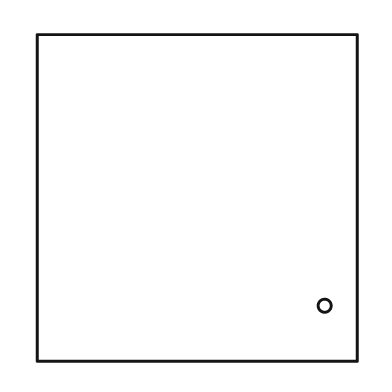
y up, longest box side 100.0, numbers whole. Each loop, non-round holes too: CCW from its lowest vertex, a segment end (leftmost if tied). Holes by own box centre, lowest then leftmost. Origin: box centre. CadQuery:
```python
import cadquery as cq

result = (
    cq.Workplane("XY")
    .moveTo(-49.0, -50.0)
    .lineTo(49.0, -50.0)
    .lineTo(49.0, 50.0)
    .lineTo(-49.0, 50.0)
    .close()
    .moveTo(39.0, -33.0)
    .circle(2.0)
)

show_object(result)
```